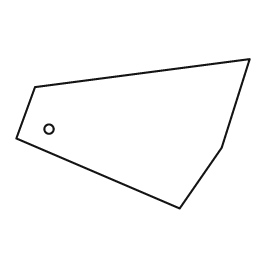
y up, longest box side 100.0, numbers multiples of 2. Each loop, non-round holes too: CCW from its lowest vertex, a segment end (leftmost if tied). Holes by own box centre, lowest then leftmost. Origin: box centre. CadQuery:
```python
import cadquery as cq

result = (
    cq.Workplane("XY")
    .moveTo(20.0, -32.0)
    .lineTo(38.0, -6.0)
    .lineTo(50.0, 32.0)
    .lineTo(-42.0, 20.0)
    .lineTo(-50.0, -2.0)
    .close()
    .moveTo(-36.0, 2.0)
    .circle(2.0)
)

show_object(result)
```